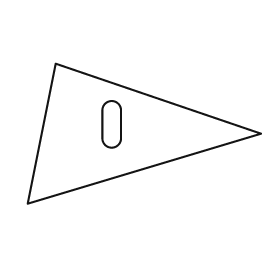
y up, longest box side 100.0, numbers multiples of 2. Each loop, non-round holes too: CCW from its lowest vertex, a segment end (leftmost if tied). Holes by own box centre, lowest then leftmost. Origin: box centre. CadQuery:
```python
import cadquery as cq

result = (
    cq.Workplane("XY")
    .moveTo(-50.0, -30.0)
    .lineTo(50.0, 0.0)
    .lineTo(-38.0, 30.0)
    .close()
    .moveTo(-18.0, -2.0)
    .threePointArc((-14.0, -6.0), (-10.0, -2.0))
    .lineTo(-10.0, 10.0)
    .threePointArc((-14.0, 14.0), (-18.0, 10.0))
    .close()
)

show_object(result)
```